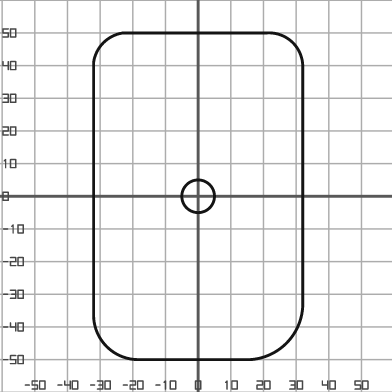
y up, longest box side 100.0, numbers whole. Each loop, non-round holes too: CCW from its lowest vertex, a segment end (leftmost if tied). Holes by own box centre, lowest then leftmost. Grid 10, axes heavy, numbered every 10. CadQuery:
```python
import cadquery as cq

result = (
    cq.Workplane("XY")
    .moveTo(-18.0, -50.0)
    .lineTo(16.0, -50.0)
    .threePointArc((27.0, -45.0), (32.0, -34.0))
    .lineTo(32.0, 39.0)
    .threePointArc((29.0, 47.0), (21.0, 50.0))
    .lineTo(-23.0, 50.0)
    .threePointArc((-29.0, 47.0), (-32.0, 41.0))
    .lineTo(-32.0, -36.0)
    .threePointArc((-28.0, -46.0), (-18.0, -50.0))
    .close()
    .moveTo(0.0, 0.0)
    .circle(5.0)
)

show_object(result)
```